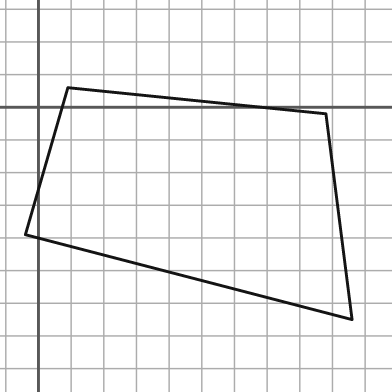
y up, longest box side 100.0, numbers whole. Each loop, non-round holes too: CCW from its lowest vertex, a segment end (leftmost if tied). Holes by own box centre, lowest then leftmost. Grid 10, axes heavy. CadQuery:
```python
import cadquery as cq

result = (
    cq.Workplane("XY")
    .moveTo(96.0, -65.0)
    .lineTo(88.0, -2.0)
    .lineTo(9.0, 6.0)
    .lineTo(-4.0, -39.0)
    .close()
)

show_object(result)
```